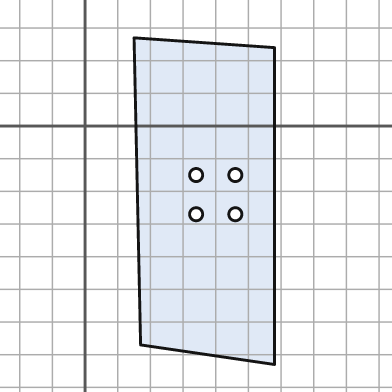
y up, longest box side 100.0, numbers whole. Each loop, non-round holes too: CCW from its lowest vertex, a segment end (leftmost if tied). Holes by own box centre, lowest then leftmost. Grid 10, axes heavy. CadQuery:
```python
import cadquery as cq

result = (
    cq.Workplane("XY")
    .moveTo(58.0, -73.0)
    .lineTo(58.0, 24.0)
    .lineTo(15.0, 27.0)
    .lineTo(17.0, -67.0)
    .close()
    .moveTo(34.0, -27.0)
    .circle(2.0)
    .moveTo(46.0, -27.0)
    .circle(2.0)
    .moveTo(34.0, -15.0)
    .circle(2.0)
    .moveTo(46.0, -15.0)
    .circle(2.0)
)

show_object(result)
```